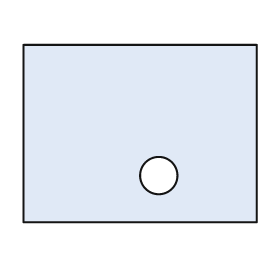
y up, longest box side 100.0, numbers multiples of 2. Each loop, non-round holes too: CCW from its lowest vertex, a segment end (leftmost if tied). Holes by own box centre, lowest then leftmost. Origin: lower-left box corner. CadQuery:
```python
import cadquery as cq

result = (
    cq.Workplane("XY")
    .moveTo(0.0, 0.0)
    .lineTo(100.0, 0.0)
    .lineTo(100.0, 76.0)
    .lineTo(0.0, 76.0)
    .close()
    .moveTo(58.0, 20.0)
    .circle(8.0)
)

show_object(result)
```